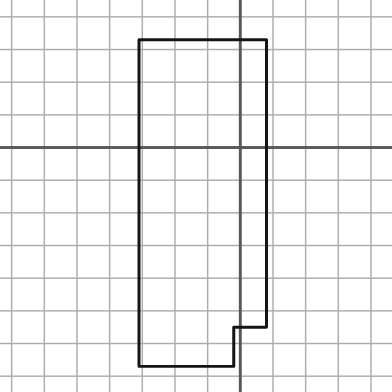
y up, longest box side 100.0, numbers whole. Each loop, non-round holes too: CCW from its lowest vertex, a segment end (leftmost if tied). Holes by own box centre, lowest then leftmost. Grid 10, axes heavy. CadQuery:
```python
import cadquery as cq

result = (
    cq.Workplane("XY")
    .moveTo(-31.0, -67.0)
    .lineTo(-2.0, -67.0)
    .lineTo(-2.0, -55.0)
    .lineTo(8.0, -55.0)
    .lineTo(8.0, 33.0)
    .lineTo(-31.0, 33.0)
    .close()
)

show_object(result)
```